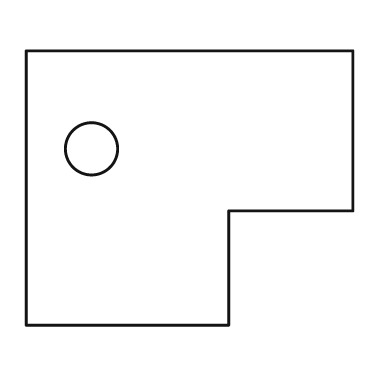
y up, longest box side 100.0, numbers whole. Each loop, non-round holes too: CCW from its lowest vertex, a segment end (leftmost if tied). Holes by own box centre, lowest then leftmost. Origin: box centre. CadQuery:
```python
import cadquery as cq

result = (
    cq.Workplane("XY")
    .moveTo(-50.0, -42.0)
    .lineTo(12.0, -42.0)
    .lineTo(12.0, -7.0)
    .lineTo(50.0, -7.0)
    .lineTo(50.0, 42.0)
    .lineTo(-50.0, 42.0)
    .close()
    .moveTo(-30.0, 12.0)
    .circle(8.0)
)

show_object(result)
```